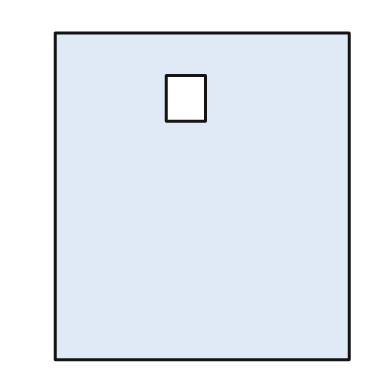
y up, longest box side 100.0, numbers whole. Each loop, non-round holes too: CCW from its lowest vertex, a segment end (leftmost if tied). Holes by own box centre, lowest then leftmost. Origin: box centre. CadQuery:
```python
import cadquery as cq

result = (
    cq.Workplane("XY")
    .moveTo(-45.0, -50.0)
    .lineTo(45.0, -50.0)
    .lineTo(45.0, 50.0)
    .lineTo(-45.0, 50.0)
    .close()
    .moveTo(-11.0, 23.0)
    .lineTo(1.0, 23.0)
    .lineTo(1.0, 37.0)
    .lineTo(-11.0, 37.0)
    .close()
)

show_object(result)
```